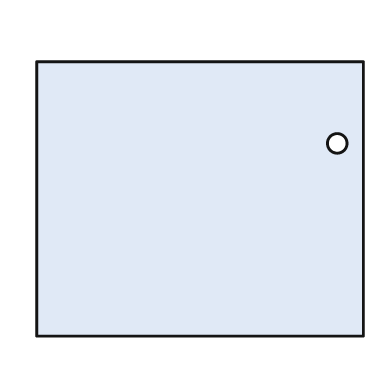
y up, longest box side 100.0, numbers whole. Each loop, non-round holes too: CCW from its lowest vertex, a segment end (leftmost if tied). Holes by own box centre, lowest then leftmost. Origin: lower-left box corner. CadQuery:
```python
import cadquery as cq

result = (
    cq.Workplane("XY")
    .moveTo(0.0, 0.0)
    .lineTo(100.0, 0.0)
    .lineTo(100.0, 84.0)
    .lineTo(0.0, 84.0)
    .close()
    .moveTo(92.0, 59.0)
    .circle(3.0)
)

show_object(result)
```